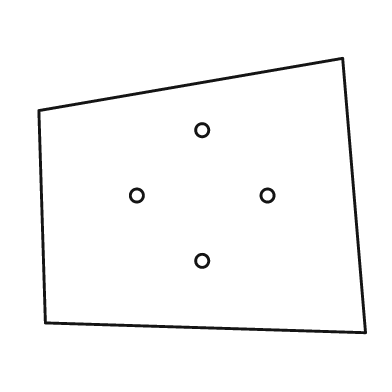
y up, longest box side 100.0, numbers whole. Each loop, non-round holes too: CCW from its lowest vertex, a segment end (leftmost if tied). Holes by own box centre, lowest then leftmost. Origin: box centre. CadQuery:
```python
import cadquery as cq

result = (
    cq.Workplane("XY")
    .moveTo(50.0, -42.0)
    .lineTo(43.0, 42.0)
    .lineTo(-50.0, 26.0)
    .lineTo(-48.0, -39.0)
    .close()
    .moveTo(0.0, -20.0)
    .circle(2.0)
    .moveTo(-20.0, 0.0)
    .circle(2.0)
    .moveTo(20.0, 0.0)
    .circle(2.0)
    .moveTo(0.0, 20.0)
    .circle(2.0)
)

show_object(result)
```